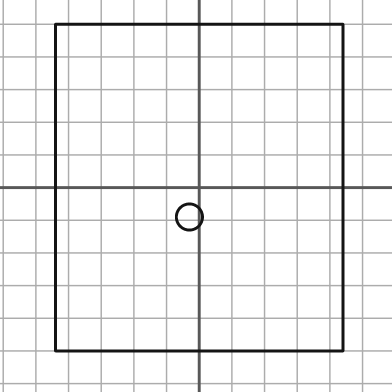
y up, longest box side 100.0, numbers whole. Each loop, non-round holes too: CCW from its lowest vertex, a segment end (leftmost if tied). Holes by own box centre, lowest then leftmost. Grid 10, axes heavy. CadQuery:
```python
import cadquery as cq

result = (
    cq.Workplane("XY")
    .moveTo(-44.0, -50.0)
    .lineTo(44.0, -50.0)
    .lineTo(44.0, 50.0)
    .lineTo(-44.0, 50.0)
    .close()
    .moveTo(-3.0, -9.0)
    .circle(4.0)
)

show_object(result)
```